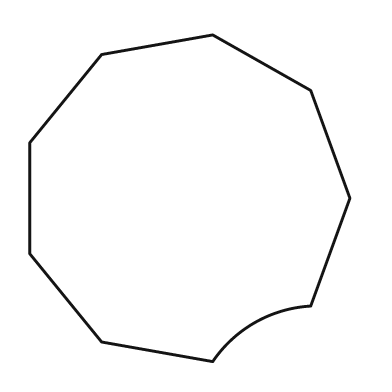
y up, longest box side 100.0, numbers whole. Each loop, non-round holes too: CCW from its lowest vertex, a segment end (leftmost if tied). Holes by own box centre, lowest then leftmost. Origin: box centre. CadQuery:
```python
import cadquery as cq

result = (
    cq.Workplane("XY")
    .moveTo(7.0, -50.0)
    .threePointArc((20.0, -38.0), (37.0, -33.0))
    .lineTo(49.0, 0.0)
    .lineTo(37.0, 33.0)
    .lineTo(7.0, 50.0)
    .lineTo(-27.0, 44.0)
    .lineTo(-49.0, 17.0)
    .lineTo(-49.0, -17.0)
    .lineTo(-27.0, -44.0)
    .close()
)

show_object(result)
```